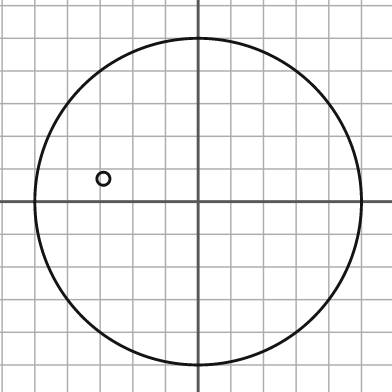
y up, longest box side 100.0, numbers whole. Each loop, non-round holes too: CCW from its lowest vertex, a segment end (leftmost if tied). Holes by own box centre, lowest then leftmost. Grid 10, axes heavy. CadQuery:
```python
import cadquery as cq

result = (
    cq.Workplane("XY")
    .moveTo(0.0, 0.0)
    .circle(50.0)
    .moveTo(-29.0, 7.0)
    .circle(2.0)
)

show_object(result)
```